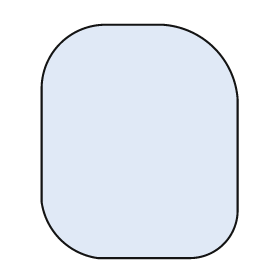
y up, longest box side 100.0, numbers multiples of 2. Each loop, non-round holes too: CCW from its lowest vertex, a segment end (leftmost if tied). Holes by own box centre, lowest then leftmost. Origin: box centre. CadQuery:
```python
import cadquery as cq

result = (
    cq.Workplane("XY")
    .moveTo(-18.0, -50.0)
    .lineTo(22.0, -50.0)
    .threePointArc((36.0, -44.0), (42.0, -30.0))
    .lineTo(42.0, 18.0)
    .threePointArc((32.0, 40.0), (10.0, 50.0))
    .lineTo(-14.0, 50.0)
    .threePointArc((-34.0, 42.0), (-42.0, 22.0))
    .lineTo(-42.0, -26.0)
    .threePointArc((-34.0, -42.0), (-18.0, -50.0))
    .close()
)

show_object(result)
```